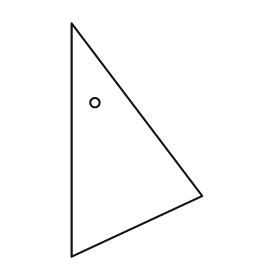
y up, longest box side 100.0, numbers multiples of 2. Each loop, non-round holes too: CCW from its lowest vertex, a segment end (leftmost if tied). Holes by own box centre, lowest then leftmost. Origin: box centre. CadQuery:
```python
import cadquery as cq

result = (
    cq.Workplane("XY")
    .moveTo(-28.0, -50.0)
    .lineTo(28.0, -24.0)
    .lineTo(-28.0, 50.0)
    .close()
    .moveTo(-18.0, 16.0)
    .circle(2.0)
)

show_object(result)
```